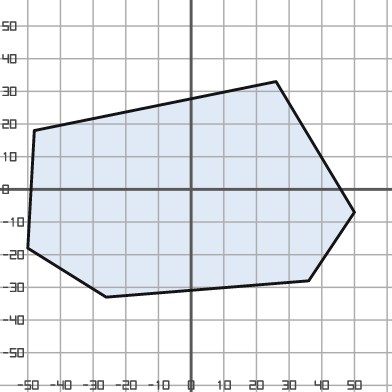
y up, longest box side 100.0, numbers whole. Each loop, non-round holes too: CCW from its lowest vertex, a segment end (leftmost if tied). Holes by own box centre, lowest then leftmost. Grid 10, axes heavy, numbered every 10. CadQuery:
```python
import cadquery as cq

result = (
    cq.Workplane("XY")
    .moveTo(-26.0, -33.0)
    .lineTo(36.0, -28.0)
    .lineTo(50.0, -7.0)
    .lineTo(26.0, 33.0)
    .lineTo(-48.0, 18.0)
    .lineTo(-50.0, -18.0)
    .close()
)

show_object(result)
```